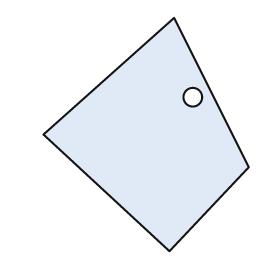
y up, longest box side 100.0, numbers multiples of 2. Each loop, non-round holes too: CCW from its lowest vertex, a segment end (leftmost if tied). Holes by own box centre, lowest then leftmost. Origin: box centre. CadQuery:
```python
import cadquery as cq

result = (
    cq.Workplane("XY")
    .moveTo(10.0, -50.0)
    .lineTo(44.0, -14.0)
    .lineTo(12.0, 50.0)
    .lineTo(-44.0, 0.0)
    .close()
    .moveTo(20.0, 16.0)
    .circle(4.0)
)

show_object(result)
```